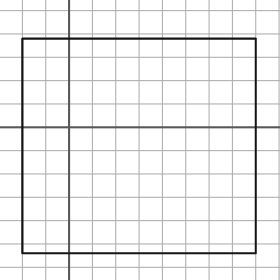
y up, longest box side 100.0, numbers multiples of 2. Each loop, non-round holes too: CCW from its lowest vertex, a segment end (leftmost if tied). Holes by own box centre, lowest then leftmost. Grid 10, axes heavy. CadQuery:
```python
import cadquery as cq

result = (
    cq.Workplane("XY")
    .moveTo(-20.0, -54.0)
    .lineTo(80.0, -54.0)
    .lineTo(80.0, 38.0)
    .lineTo(-20.0, 38.0)
    .close()
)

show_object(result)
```